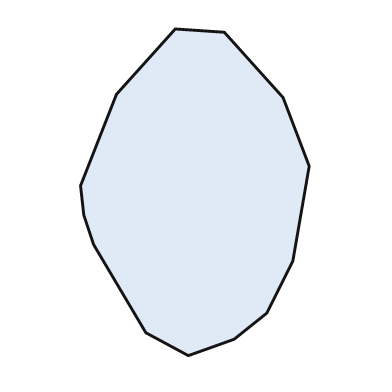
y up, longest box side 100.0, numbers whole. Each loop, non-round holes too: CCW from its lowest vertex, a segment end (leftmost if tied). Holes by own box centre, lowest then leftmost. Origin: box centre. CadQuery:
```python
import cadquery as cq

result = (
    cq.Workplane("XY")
    .moveTo(-2.0, -50.0)
    .lineTo(12.0, -45.0)
    .lineTo(22.0, -37.0)
    .lineTo(30.0, -21.0)
    .lineTo(35.0, 8.0)
    .lineTo(27.0, 29.0)
    .lineTo(9.0, 49.0)
    .lineTo(-6.0, 50.0)
    .lineTo(-24.0, 30.0)
    .lineTo(-35.0, 2.0)
    .lineTo(-34.0, -7.0)
    .lineTo(-31.0, -16.0)
    .lineTo(-15.0, -43.0)
    .close()
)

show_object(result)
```